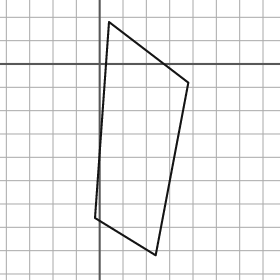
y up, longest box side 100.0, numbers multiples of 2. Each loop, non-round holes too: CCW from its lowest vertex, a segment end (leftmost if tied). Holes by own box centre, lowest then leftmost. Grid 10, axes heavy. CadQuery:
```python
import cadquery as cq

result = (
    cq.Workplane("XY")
    .moveTo(24.0, -82.0)
    .lineTo(38.0, -8.0)
    .lineTo(4.0, 18.0)
    .lineTo(-2.0, -66.0)
    .close()
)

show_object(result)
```